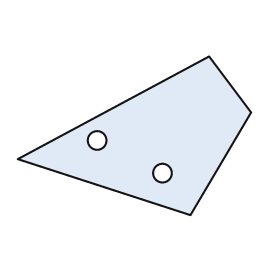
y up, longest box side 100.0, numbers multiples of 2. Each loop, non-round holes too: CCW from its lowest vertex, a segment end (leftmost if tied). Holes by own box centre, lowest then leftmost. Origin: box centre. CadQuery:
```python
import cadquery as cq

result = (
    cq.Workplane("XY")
    .moveTo(24.0, -34.0)
    .lineTo(50.0, 10.0)
    .lineTo(32.0, 34.0)
    .lineTo(-50.0, -10.0)
    .close()
    .moveTo(12.0, -16.0)
    .circle(4.0)
    .moveTo(-16.0, -2.0)
    .circle(4.0)
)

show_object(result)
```